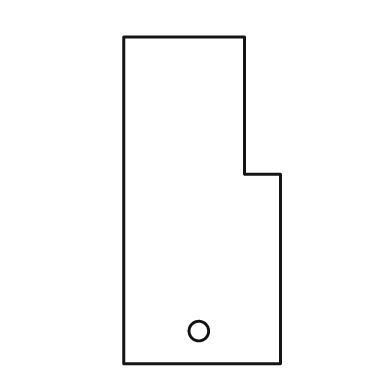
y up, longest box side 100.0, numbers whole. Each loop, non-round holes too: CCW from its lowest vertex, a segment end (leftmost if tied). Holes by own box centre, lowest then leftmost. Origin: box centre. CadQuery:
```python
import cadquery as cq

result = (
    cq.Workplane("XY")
    .moveTo(-24.0, -50.0)
    .lineTo(24.0, -50.0)
    .lineTo(24.0, 8.0)
    .lineTo(13.0, 8.0)
    .lineTo(13.0, 50.0)
    .lineTo(-24.0, 50.0)
    .close()
    .moveTo(-1.0, -40.0)
    .circle(3.0)
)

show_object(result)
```